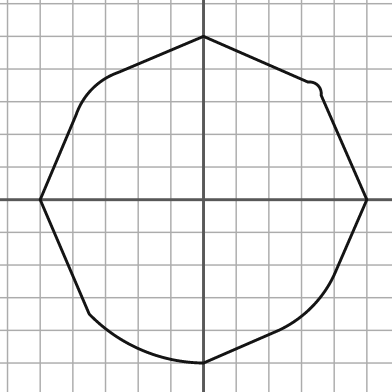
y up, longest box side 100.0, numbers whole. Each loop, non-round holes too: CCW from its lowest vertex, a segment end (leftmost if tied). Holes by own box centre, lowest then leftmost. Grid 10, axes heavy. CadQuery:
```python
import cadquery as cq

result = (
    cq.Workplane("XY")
    .moveTo(0.0, -50.0)
    .lineTo(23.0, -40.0)
    .threePointArc((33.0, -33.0), (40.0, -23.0))
    .lineTo(50.0, 0.0)
    .lineTo(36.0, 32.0)
    .threePointArc((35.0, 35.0), (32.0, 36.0))
    .lineTo(0.0, 50.0)
    .lineTo(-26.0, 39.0)
    .threePointArc((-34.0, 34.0), (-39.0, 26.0))
    .lineTo(-50.0, 0.0)
    .lineTo(-35.0, -35.0)
    .threePointArc((-19.0, -46.0), (0.0, -50.0))
    .close()
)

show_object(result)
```